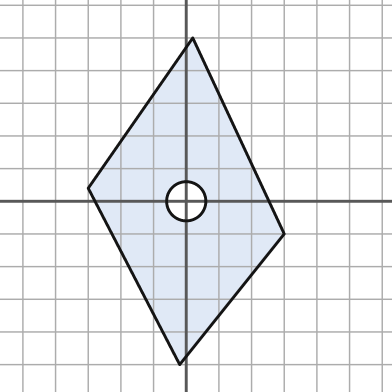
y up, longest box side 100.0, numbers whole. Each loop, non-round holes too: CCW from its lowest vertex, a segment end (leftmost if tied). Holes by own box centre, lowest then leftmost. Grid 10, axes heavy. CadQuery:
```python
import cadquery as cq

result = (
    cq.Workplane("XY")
    .moveTo(-2.0, -50.0)
    .lineTo(30.0, -10.0)
    .lineTo(2.0, 50.0)
    .lineTo(-30.0, 4.0)
    .close()
    .moveTo(0.0, 0.0)
    .circle(6.0)
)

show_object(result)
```